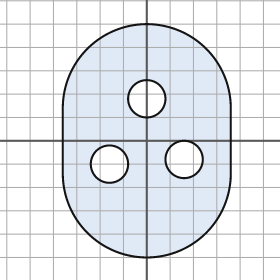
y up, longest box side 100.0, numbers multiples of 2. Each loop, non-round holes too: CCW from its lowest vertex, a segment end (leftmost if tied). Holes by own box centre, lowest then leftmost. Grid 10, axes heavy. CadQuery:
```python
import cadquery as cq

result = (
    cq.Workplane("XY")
    .moveTo(-36.0, -14.0)
    .threePointArc((0.0, -50.0), (36.0, -14.0))
    .lineTo(36.0, 14.0)
    .threePointArc((0.0, 50.0), (-36.0, 14.0))
    .close()
    .moveTo(-16.0, -10.0)
    .circle(8.0)
    .moveTo(16.0, -8.0)
    .circle(8.0)
    .moveTo(0.0, 18.0)
    .circle(8.0)
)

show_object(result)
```